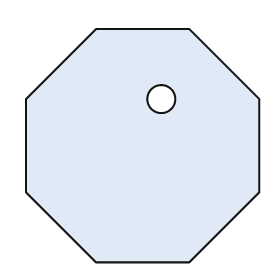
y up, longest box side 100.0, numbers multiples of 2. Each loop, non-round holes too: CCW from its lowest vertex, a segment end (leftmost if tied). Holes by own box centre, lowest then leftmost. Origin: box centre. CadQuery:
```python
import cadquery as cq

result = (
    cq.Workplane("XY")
    .moveTo(-20.0, -50.0)
    .lineTo(20.0, -50.0)
    .lineTo(50.0, -20.0)
    .lineTo(50.0, 20.0)
    .lineTo(20.0, 50.0)
    .lineTo(-20.0, 50.0)
    .lineTo(-50.0, 20.0)
    .lineTo(-50.0, -20.0)
    .close()
    .moveTo(8.0, 20.0)
    .circle(6.0)
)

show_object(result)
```